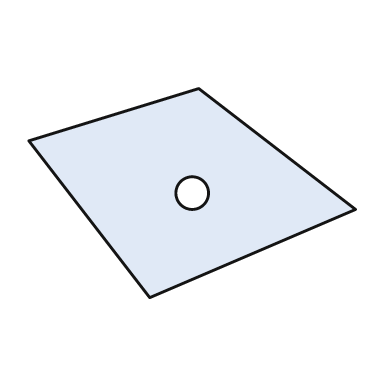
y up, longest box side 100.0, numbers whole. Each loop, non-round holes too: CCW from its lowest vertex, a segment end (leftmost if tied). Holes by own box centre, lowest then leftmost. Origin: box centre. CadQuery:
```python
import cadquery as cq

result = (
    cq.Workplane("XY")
    .moveTo(-13.0, -32.0)
    .lineTo(50.0, -5.0)
    .lineTo(2.0, 32.0)
    .lineTo(-50.0, 16.0)
    .close()
    .moveTo(0.0, 0.0)
    .circle(5.0)
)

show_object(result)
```